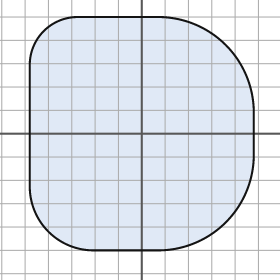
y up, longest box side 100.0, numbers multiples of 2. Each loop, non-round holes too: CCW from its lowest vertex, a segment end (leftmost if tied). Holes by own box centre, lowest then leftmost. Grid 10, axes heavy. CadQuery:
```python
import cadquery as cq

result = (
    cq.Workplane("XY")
    .moveTo(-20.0, -50.0)
    .lineTo(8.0, -50.0)
    .threePointArc((36.0, -38.0), (48.0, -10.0))
    .lineTo(48.0, 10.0)
    .threePointArc((36.0, 38.0), (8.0, 50.0))
    .lineTo(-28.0, 50.0)
    .threePointArc((-42.0, 44.0), (-48.0, 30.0))
    .lineTo(-48.0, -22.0)
    .threePointArc((-40.0, -42.0), (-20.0, -50.0))
    .close()
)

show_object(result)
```